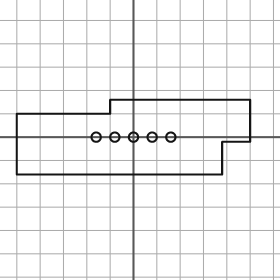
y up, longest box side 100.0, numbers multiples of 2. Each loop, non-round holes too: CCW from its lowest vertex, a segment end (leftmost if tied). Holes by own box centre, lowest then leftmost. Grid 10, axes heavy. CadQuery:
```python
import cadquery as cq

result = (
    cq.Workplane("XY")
    .moveTo(-50.0, -16.0)
    .lineTo(38.0, -16.0)
    .lineTo(38.0, -2.0)
    .lineTo(50.0, -2.0)
    .lineTo(50.0, 16.0)
    .lineTo(-10.0, 16.0)
    .lineTo(-10.0, 10.0)
    .lineTo(-50.0, 10.0)
    .close()
    .moveTo(-16.0, 0.0)
    .circle(2.0)
    .moveTo(-8.0, 0.0)
    .circle(2.0)
    .moveTo(0.0, 0.0)
    .circle(2.0)
    .moveTo(8.0, 0.0)
    .circle(2.0)
    .moveTo(16.0, 0.0)
    .circle(2.0)
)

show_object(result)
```